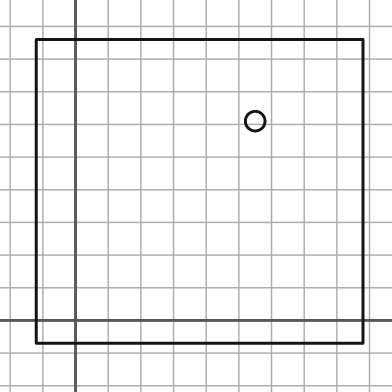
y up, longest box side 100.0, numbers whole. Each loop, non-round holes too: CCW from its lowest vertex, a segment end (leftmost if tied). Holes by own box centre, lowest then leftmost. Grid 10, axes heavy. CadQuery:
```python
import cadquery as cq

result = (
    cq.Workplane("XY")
    .moveTo(-12.0, -7.0)
    .lineTo(88.0, -7.0)
    .lineTo(88.0, 86.0)
    .lineTo(-12.0, 86.0)
    .close()
    .moveTo(55.0, 61.0)
    .circle(3.0)
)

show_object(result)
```